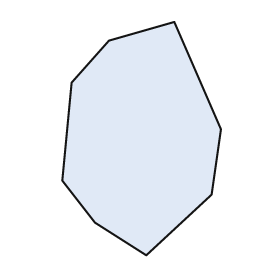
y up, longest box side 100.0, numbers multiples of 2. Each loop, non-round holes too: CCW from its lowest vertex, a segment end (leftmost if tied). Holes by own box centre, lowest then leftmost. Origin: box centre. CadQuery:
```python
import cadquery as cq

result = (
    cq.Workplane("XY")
    .moveTo(2.0, -50.0)
    .lineTo(30.0, -24.0)
    .lineTo(34.0, 4.0)
    .lineTo(14.0, 50.0)
    .lineTo(-14.0, 42.0)
    .lineTo(-30.0, 24.0)
    .lineTo(-34.0, -18.0)
    .lineTo(-20.0, -36.0)
    .close()
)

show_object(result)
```